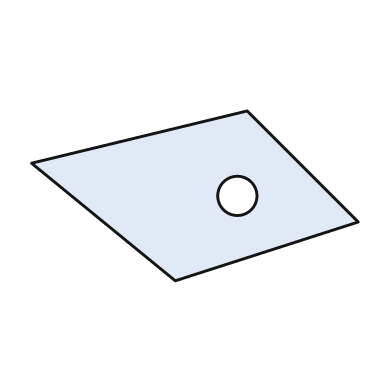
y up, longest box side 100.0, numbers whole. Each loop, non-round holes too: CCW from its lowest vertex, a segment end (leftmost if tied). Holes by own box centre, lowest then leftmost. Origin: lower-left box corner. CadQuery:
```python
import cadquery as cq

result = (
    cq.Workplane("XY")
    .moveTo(44.0, 0.0)
    .lineTo(100.0, 18.0)
    .lineTo(66.0, 52.0)
    .lineTo(0.0, 36.0)
    .close()
    .moveTo(63.0, 26.0)
    .circle(6.0)
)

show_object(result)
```